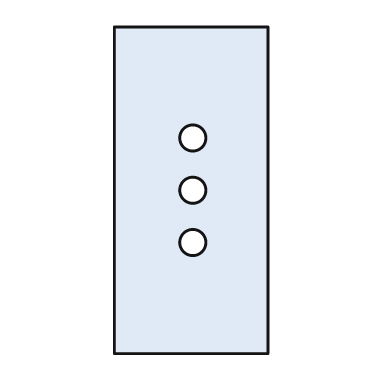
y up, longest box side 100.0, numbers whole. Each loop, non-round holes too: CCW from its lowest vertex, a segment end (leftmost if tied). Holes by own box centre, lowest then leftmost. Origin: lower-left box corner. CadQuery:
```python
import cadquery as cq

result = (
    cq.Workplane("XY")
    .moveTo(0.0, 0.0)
    .lineTo(47.0, 0.0)
    .lineTo(47.0, 100.0)
    .lineTo(0.0, 100.0)
    .close()
    .moveTo(24.0, 34.0)
    .circle(4.0)
    .moveTo(24.0, 50.0)
    .circle(4.0)
    .moveTo(24.0, 66.0)
    .circle(4.0)
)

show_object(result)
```